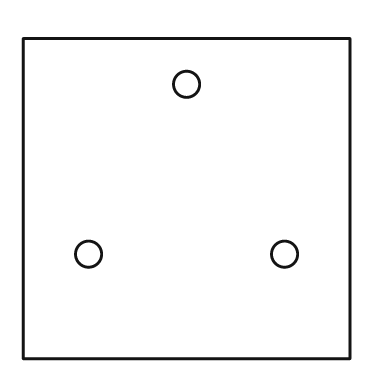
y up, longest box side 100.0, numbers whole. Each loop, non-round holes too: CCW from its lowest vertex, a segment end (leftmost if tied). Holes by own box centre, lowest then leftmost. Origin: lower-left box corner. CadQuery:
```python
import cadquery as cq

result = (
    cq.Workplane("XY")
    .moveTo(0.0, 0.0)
    .lineTo(100.0, 0.0)
    .lineTo(100.0, 98.0)
    .lineTo(0.0, 98.0)
    .close()
    .moveTo(20.0, 32.0)
    .circle(4.0)
    .moveTo(80.0, 32.0)
    .circle(4.0)
    .moveTo(50.0, 84.0)
    .circle(4.0)
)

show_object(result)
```